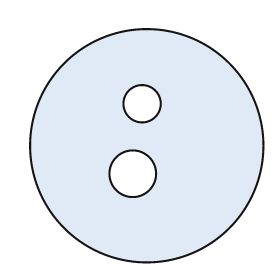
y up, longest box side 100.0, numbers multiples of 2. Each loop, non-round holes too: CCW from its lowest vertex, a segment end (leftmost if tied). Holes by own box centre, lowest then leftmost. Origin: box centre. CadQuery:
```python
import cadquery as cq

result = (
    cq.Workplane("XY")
    .moveTo(0.0, 0.0)
    .circle(50.0)
    .moveTo(-6.0, -12.0)
    .circle(10.0)
    .moveTo(-2.0, 18.0)
    .circle(8.0)
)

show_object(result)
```